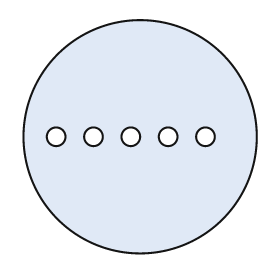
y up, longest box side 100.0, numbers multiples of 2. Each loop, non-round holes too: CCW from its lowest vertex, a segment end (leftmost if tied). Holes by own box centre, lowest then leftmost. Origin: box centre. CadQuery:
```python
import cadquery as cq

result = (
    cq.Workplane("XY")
    .moveTo(0.0, 0.0)
    .circle(50.0)
    .moveTo(-36.0, 0.0)
    .circle(4.0)
    .moveTo(-20.0, 0.0)
    .circle(4.0)
    .moveTo(-4.0, 0.0)
    .circle(4.0)
    .moveTo(12.0, 0.0)
    .circle(4.0)
    .moveTo(28.0, 0.0)
    .circle(4.0)
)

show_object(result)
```